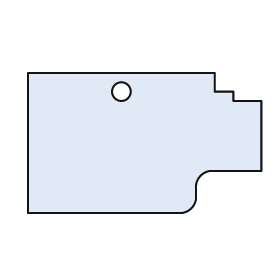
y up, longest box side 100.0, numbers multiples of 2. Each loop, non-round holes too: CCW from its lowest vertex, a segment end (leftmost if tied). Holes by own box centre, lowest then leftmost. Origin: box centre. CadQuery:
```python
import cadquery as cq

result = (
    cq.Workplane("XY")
    .moveTo(-50.0, -30.0)
    .lineTo(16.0, -30.0)
    .threePointArc((20.0, -28.0), (22.0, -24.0))
    .lineTo(22.0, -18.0)
    .threePointArc((24.0, -14.0), (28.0, -12.0))
    .lineTo(50.0, -12.0)
    .lineTo(50.0, 18.0)
    .lineTo(38.0, 18.0)
    .lineTo(38.0, 22.0)
    .lineTo(30.0, 22.0)
    .lineTo(30.0, 30.0)
    .lineTo(-50.0, 30.0)
    .close()
    .moveTo(-10.0, 22.0)
    .circle(4.0)
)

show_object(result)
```